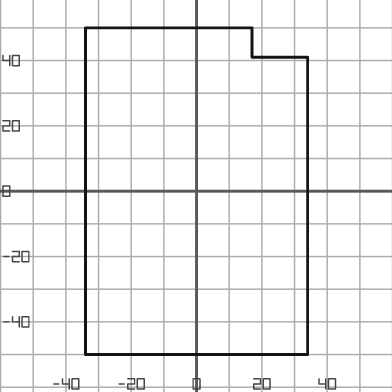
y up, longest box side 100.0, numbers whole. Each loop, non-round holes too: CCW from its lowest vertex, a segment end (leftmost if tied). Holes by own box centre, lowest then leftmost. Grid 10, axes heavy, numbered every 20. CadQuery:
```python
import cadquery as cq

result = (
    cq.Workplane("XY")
    .moveTo(-34.0, -50.0)
    .lineTo(34.0, -50.0)
    .lineTo(34.0, 41.0)
    .lineTo(17.0, 41.0)
    .lineTo(17.0, 50.0)
    .lineTo(-34.0, 50.0)
    .close()
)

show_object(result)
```